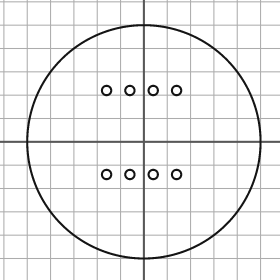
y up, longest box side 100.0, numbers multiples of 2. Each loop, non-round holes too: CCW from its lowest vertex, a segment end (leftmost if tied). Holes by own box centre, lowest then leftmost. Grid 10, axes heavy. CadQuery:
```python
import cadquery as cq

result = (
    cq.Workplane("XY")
    .moveTo(0.0, 0.0)
    .circle(50.0)
    .moveTo(-16.0, -14.0)
    .circle(2.0)
    .moveTo(-6.0, -14.0)
    .circle(2.0)
    .moveTo(4.0, -14.0)
    .circle(2.0)
    .moveTo(14.0, -14.0)
    .circle(2.0)
    .moveTo(-16.0, 22.0)
    .circle(2.0)
    .moveTo(-6.0, 22.0)
    .circle(2.0)
    .moveTo(4.0, 22.0)
    .circle(2.0)
    .moveTo(14.0, 22.0)
    .circle(2.0)
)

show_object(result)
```